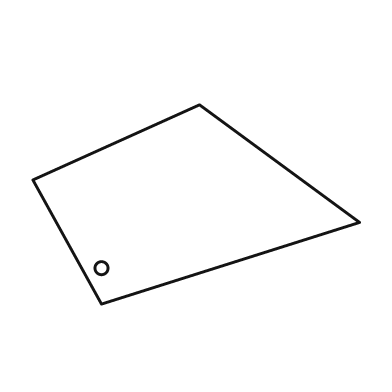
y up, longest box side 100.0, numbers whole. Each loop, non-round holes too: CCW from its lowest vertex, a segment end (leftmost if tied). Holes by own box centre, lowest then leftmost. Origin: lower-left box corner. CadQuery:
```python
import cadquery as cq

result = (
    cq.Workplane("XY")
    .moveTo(21.0, 0.0)
    .lineTo(100.0, 25.0)
    .lineTo(51.0, 61.0)
    .lineTo(0.0, 38.0)
    .close()
    .moveTo(21.0, 11.0)
    .circle(2.0)
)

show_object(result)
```